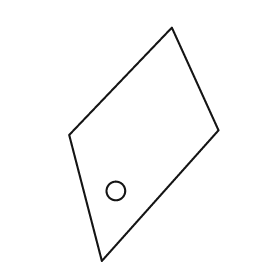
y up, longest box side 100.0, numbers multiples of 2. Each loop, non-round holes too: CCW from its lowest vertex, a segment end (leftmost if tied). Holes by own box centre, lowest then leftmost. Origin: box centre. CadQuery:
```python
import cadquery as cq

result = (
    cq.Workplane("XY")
    .moveTo(-18.0, -50.0)
    .lineTo(32.0, 6.0)
    .lineTo(12.0, 50.0)
    .lineTo(-32.0, 4.0)
    .close()
    .moveTo(-12.0, -20.0)
    .circle(4.0)
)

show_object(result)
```